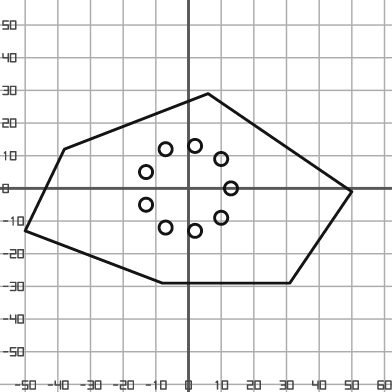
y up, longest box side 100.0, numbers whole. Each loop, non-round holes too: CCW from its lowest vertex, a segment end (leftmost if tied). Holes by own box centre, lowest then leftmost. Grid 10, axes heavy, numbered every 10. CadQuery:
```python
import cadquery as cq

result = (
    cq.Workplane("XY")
    .moveTo(-8.0, -29.0)
    .lineTo(31.0, -29.0)
    .lineTo(50.0, -1.0)
    .lineTo(6.0, 29.0)
    .lineTo(-38.0, 12.0)
    .lineTo(-50.0, -13.0)
    .close()
    .moveTo(2.0, -13.0)
    .circle(2.0)
    .moveTo(-7.0, -12.0)
    .circle(2.0)
    .moveTo(10.0, -9.0)
    .circle(2.0)
    .moveTo(-13.0, -5.0)
    .circle(2.0)
    .moveTo(13.0, 0.0)
    .circle(2.0)
    .moveTo(-13.0, 5.0)
    .circle(2.0)
    .moveTo(10.0, 9.0)
    .circle(2.0)
    .moveTo(-7.0, 12.0)
    .circle(2.0)
    .moveTo(2.0, 13.0)
    .circle(2.0)
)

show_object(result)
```